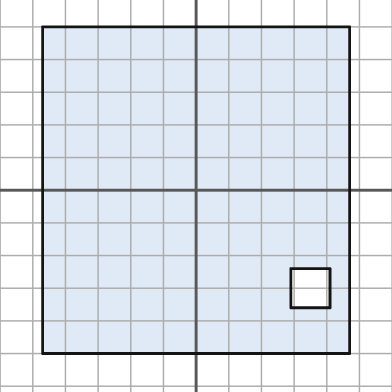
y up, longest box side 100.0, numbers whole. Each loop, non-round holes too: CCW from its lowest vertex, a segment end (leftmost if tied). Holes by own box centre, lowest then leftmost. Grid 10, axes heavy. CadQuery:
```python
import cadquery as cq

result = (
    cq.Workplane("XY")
    .moveTo(-47.0, -50.0)
    .lineTo(47.0, -50.0)
    .lineTo(47.0, 50.0)
    .lineTo(-47.0, 50.0)
    .close()
    .moveTo(29.0, -36.0)
    .lineTo(41.0, -36.0)
    .lineTo(41.0, -24.0)
    .lineTo(29.0, -24.0)
    .close()
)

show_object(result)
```